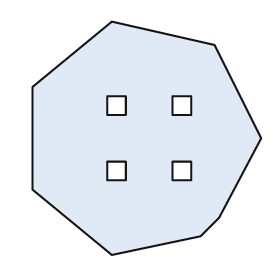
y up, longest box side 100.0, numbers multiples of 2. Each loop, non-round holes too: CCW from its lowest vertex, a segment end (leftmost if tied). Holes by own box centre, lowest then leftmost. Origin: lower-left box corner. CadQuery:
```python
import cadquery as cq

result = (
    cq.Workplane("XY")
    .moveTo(34.0, 0.0)
    .lineTo(72.0, 8.0)
    .lineTo(80.0, 16.0)
    .lineTo(98.0, 50.0)
    .lineTo(78.0, 90.0)
    .lineTo(34.0, 100.0)
    .lineTo(0.0, 72.0)
    .lineTo(0.0, 28.0)
    .close()
    .moveTo(32.0, 32.0)
    .lineTo(40.0, 32.0)
    .lineTo(40.0, 40.0)
    .lineTo(32.0, 40.0)
    .close()
    .moveTo(60.0, 32.0)
    .lineTo(68.0, 32.0)
    .lineTo(68.0, 40.0)
    .lineTo(60.0, 40.0)
    .close()
    .moveTo(32.0, 60.0)
    .lineTo(40.0, 60.0)
    .lineTo(40.0, 68.0)
    .lineTo(32.0, 68.0)
    .close()
    .moveTo(60.0, 60.0)
    .lineTo(68.0, 60.0)
    .lineTo(68.0, 68.0)
    .lineTo(60.0, 68.0)
    .close()
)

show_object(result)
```